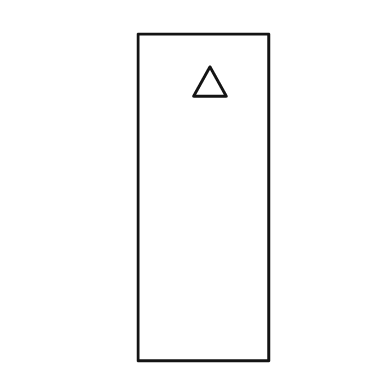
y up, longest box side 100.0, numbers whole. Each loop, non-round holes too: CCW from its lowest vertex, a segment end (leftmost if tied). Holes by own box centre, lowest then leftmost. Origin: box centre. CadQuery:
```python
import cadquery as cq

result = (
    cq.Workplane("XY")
    .moveTo(-20.0, -50.0)
    .lineTo(20.0, -50.0)
    .lineTo(20.0, 50.0)
    .lineTo(-20.0, 50.0)
    .close()
    .moveTo(-3.0, 31.0)
    .lineTo(7.0, 31.0)
    .lineTo(2.0, 40.0)
    .close()
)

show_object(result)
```